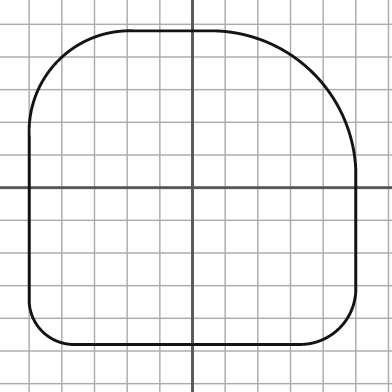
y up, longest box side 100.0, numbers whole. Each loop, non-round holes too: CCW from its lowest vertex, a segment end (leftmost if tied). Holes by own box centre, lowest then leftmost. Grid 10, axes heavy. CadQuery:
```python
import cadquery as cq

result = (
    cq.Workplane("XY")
    .moveTo(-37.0, -48.0)
    .lineTo(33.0, -48.0)
    .threePointArc((45.0, -43.0), (50.0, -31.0))
    .lineTo(50.0, 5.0)
    .threePointArc((37.0, 35.0), (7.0, 48.0))
    .lineTo(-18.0, 48.0)
    .threePointArc((-41.0, 39.0), (-50.0, 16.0))
    .lineTo(-50.0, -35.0)
    .threePointArc((-46.0, -44.0), (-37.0, -48.0))
    .close()
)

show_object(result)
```